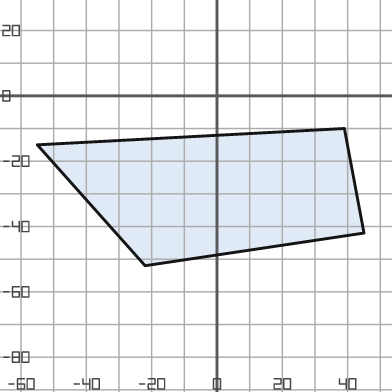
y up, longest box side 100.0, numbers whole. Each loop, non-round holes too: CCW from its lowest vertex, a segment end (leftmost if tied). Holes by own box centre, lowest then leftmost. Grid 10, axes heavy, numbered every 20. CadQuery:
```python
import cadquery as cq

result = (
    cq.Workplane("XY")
    .moveTo(-22.0, -52.0)
    .lineTo(45.0, -42.0)
    .lineTo(39.0, -10.0)
    .lineTo(-55.0, -15.0)
    .close()
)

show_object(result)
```